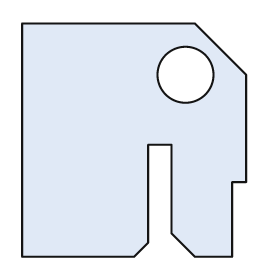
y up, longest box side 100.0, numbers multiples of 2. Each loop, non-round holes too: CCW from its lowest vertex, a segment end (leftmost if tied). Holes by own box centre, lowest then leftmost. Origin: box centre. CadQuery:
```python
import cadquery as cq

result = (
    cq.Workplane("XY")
    .moveTo(-48.0, -50.0)
    .lineTo(0.0, -50.0)
    .lineTo(6.0, -44.0)
    .lineTo(6.0, -2.0)
    .lineTo(16.0, -2.0)
    .lineTo(16.0, -40.0)
    .lineTo(26.0, -50.0)
    .lineTo(42.0, -50.0)
    .lineTo(42.0, -18.0)
    .lineTo(48.0, -18.0)
    .lineTo(48.0, 28.0)
    .lineTo(26.0, 50.0)
    .lineTo(-48.0, 50.0)
    .close()
    .moveTo(22.0, 28.0)
    .circle(12.0)
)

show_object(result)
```